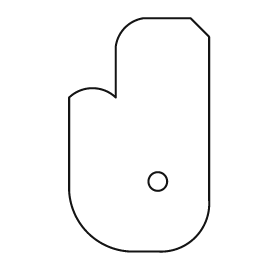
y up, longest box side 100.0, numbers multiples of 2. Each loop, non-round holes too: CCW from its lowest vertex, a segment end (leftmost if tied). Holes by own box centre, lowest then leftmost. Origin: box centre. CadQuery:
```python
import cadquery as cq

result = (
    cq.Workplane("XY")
    .moveTo(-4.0, -50.0)
    .lineTo(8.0, -50.0)
    .threePointArc((24.0, -44.0), (30.0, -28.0))
    .lineTo(30.0, 42.0)
    .lineTo(22.0, 50.0)
    .lineTo(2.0, 50.0)
    .threePointArc((-6.0, 46.0), (-10.0, 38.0))
    .lineTo(-10.0, 16.0)
    .threePointArc((-20.0, 20.0), (-30.0, 16.0))
    .lineTo(-30.0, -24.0)
    .threePointArc((-22.0, -42.0), (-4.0, -50.0))
    .close()
    .moveTo(8.0, -20.0)
    .circle(4.0)
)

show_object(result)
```